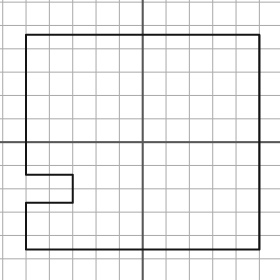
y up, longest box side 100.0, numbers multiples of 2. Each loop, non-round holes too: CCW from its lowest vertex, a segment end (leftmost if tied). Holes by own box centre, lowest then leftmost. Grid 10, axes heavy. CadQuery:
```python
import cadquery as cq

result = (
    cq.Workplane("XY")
    .moveTo(-50.0, -46.0)
    .lineTo(50.0, -46.0)
    .lineTo(50.0, 46.0)
    .lineTo(-50.0, 46.0)
    .lineTo(-50.0, -14.0)
    .lineTo(-30.0, -14.0)
    .lineTo(-30.0, -26.0)
    .lineTo(-50.0, -26.0)
    .close()
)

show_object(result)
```